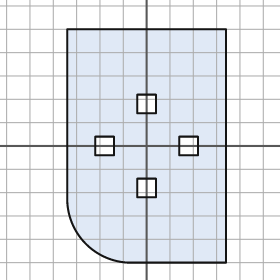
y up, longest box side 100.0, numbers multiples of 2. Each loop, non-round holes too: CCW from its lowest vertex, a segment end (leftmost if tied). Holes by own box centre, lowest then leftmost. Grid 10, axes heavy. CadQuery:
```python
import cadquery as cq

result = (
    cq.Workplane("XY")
    .moveTo(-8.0, -50.0)
    .lineTo(34.0, -50.0)
    .lineTo(34.0, 50.0)
    .lineTo(-34.0, 50.0)
    .lineTo(-34.0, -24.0)
    .threePointArc((-26.0, -42.0), (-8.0, -50.0))
    .close()
    .moveTo(-4.0, -22.0)
    .lineTo(4.0, -22.0)
    .lineTo(4.0, -14.0)
    .lineTo(-4.0, -14.0)
    .close()
    .moveTo(-22.0, -4.0)
    .lineTo(-14.0, -4.0)
    .lineTo(-14.0, 4.0)
    .lineTo(-22.0, 4.0)
    .close()
    .moveTo(14.0, -4.0)
    .lineTo(22.0, -4.0)
    .lineTo(22.0, 4.0)
    .lineTo(14.0, 4.0)
    .close()
    .moveTo(-4.0, 14.0)
    .lineTo(4.0, 14.0)
    .lineTo(4.0, 22.0)
    .lineTo(-4.0, 22.0)
    .close()
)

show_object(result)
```